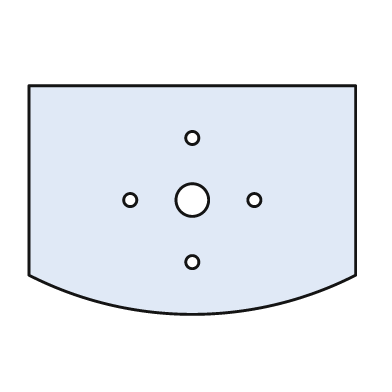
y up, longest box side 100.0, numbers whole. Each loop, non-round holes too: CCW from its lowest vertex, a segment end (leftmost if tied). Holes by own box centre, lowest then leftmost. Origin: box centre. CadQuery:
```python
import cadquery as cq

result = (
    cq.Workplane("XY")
    .moveTo(-50.0, -23.0)
    .threePointArc((0.0, -35.0), (50.0, -23.0))
    .lineTo(50.0, 35.0)
    .lineTo(-50.0, 35.0)
    .close()
    .moveTo(0.0, -19.0)
    .circle(2.0)
    .moveTo(-19.0, 0.0)
    .circle(2.0)
    .moveTo(0.0, 0.0)
    .circle(5.0)
    .moveTo(19.0, 0.0)
    .circle(2.0)
    .moveTo(0.0, 19.0)
    .circle(2.0)
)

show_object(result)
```